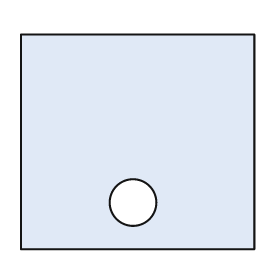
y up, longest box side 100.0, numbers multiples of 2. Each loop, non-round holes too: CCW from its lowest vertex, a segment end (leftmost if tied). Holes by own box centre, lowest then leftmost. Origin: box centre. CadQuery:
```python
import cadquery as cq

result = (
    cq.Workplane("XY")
    .moveTo(-50.0, -46.0)
    .lineTo(50.0, -46.0)
    .lineTo(50.0, 46.0)
    .lineTo(-50.0, 46.0)
    .close()
    .moveTo(-2.0, -26.0)
    .circle(10.0)
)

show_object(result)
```